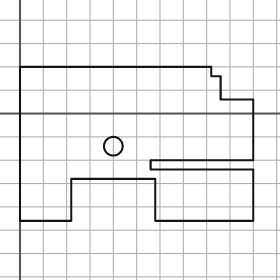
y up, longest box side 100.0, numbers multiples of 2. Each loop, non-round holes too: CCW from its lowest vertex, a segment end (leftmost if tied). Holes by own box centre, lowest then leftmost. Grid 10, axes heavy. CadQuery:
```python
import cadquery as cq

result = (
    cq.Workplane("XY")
    .moveTo(0.0, -46.0)
    .lineTo(22.0, -46.0)
    .lineTo(22.0, -28.0)
    .lineTo(58.0, -28.0)
    .lineTo(58.0, -46.0)
    .lineTo(100.0, -46.0)
    .lineTo(100.0, -24.0)
    .lineTo(56.0, -24.0)
    .lineTo(56.0, -20.0)
    .lineTo(100.0, -20.0)
    .lineTo(100.0, 6.0)
    .lineTo(86.0, 6.0)
    .lineTo(86.0, 16.0)
    .lineTo(82.0, 16.0)
    .lineTo(82.0, 20.0)
    .lineTo(0.0, 20.0)
    .close()
    .moveTo(40.0, -14.0)
    .circle(4.0)
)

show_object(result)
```